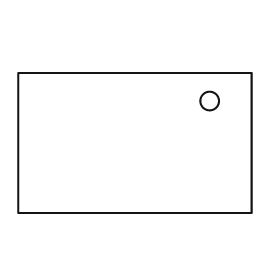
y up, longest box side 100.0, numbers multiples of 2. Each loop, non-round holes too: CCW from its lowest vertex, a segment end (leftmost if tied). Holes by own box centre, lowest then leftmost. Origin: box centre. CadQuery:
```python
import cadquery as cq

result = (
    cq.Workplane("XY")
    .moveTo(-50.0, -30.0)
    .lineTo(50.0, -30.0)
    .lineTo(50.0, 30.0)
    .lineTo(-50.0, 30.0)
    .close()
    .moveTo(32.0, 18.0)
    .circle(4.0)
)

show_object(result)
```